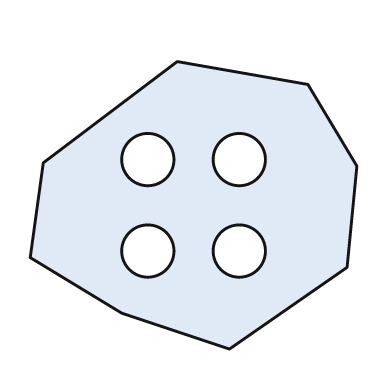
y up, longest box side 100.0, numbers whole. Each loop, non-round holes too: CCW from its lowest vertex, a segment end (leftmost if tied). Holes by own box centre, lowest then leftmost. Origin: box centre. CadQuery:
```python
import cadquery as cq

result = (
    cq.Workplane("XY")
    .moveTo(11.0, -44.0)
    .lineTo(47.0, -19.0)
    .lineTo(50.0, 12.0)
    .lineTo(35.0, 37.0)
    .lineTo(-5.0, 44.0)
    .lineTo(-46.0, 13.0)
    .lineTo(-50.0, -16.0)
    .lineTo(-22.0, -33.0)
    .close()
    .moveTo(-14.0, -14.0)
    .circle(8.0)
    .moveTo(14.0, -14.0)
    .circle(8.0)
    .moveTo(-14.0, 14.0)
    .circle(8.0)
    .moveTo(14.0, 14.0)
    .circle(8.0)
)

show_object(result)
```